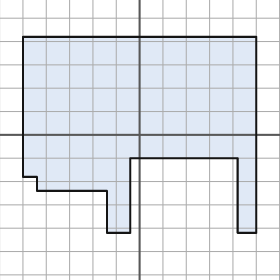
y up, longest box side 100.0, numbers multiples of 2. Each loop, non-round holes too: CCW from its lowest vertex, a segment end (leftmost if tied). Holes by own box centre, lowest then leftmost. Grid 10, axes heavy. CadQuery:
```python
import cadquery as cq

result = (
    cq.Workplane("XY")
    .moveTo(-14.0, -42.0)
    .lineTo(-4.0, -42.0)
    .lineTo(-4.0, -10.0)
    .lineTo(42.0, -10.0)
    .lineTo(42.0, -42.0)
    .lineTo(50.0, -42.0)
    .lineTo(50.0, 42.0)
    .lineTo(-50.0, 42.0)
    .lineTo(-50.0, -18.0)
    .lineTo(-44.0, -18.0)
    .lineTo(-44.0, -24.0)
    .lineTo(-14.0, -24.0)
    .close()
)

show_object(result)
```